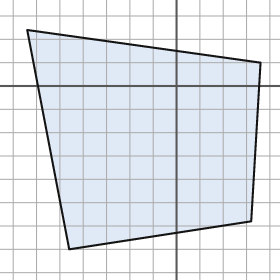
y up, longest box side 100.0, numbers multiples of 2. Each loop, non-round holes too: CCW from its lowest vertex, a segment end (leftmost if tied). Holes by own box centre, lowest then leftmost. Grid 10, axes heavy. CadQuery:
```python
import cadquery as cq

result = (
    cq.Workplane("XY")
    .moveTo(-46.0, -70.0)
    .lineTo(32.0, -58.0)
    .lineTo(36.0, 10.0)
    .lineTo(-64.0, 24.0)
    .close()
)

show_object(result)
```